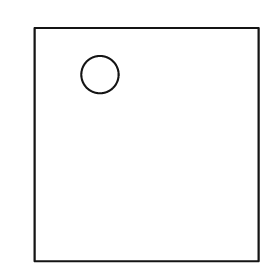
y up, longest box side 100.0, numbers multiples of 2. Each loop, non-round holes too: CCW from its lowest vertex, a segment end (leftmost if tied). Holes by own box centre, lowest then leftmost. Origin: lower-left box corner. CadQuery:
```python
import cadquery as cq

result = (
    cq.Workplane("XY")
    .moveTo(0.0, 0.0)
    .lineTo(96.0, 0.0)
    .lineTo(96.0, 100.0)
    .lineTo(0.0, 100.0)
    .close()
    .moveTo(28.0, 80.0)
    .circle(8.0)
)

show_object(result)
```